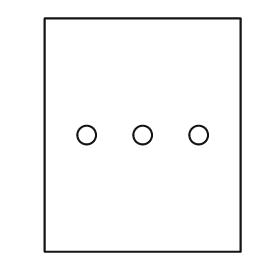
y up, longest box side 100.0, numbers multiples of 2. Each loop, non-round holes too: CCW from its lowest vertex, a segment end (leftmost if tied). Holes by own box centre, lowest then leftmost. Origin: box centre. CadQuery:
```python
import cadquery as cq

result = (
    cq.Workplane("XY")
    .moveTo(-42.0, -50.0)
    .lineTo(42.0, -50.0)
    .lineTo(42.0, 50.0)
    .lineTo(-42.0, 50.0)
    .close()
    .moveTo(-24.0, 0.0)
    .circle(4.0)
    .moveTo(0.0, 0.0)
    .circle(4.0)
    .moveTo(24.0, 0.0)
    .circle(4.0)
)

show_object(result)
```